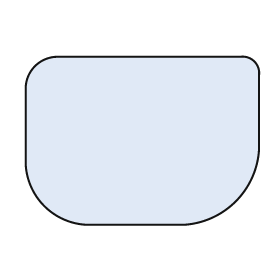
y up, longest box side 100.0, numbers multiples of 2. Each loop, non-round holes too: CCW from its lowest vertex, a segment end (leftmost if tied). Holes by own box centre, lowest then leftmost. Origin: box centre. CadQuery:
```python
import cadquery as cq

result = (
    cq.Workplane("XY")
    .moveTo(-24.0, -36.0)
    .lineTo(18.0, -36.0)
    .threePointArc((40.0, -26.0), (50.0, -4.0))
    .lineTo(50.0, 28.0)
    .threePointArc((48.0, 34.0), (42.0, 36.0))
    .lineTo(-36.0, 36.0)
    .threePointArc((-46.0, 32.0), (-50.0, 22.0))
    .lineTo(-50.0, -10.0)
    .threePointArc((-42.0, -28.0), (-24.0, -36.0))
    .close()
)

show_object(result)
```